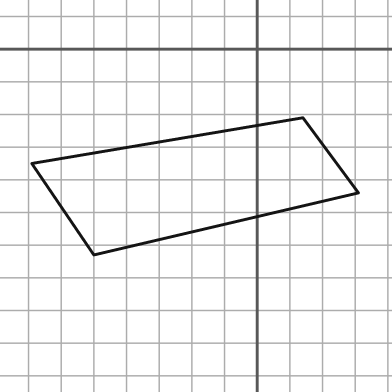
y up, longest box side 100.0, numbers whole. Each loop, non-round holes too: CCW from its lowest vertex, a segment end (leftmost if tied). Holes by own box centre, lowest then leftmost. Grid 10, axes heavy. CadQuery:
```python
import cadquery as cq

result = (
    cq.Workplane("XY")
    .moveTo(-50.0, -63.0)
    .lineTo(31.0, -44.0)
    .lineTo(14.0, -21.0)
    .lineTo(-69.0, -35.0)
    .close()
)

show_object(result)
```